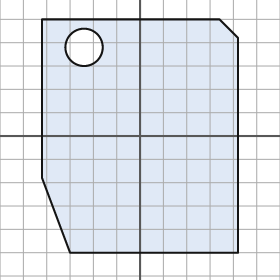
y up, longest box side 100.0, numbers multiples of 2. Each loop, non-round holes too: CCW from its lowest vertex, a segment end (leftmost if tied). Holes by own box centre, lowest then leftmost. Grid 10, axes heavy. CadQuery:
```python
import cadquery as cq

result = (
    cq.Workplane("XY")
    .moveTo(-30.0, -50.0)
    .lineTo(42.0, -50.0)
    .lineTo(42.0, 42.0)
    .lineTo(34.0, 50.0)
    .lineTo(-42.0, 50.0)
    .lineTo(-42.0, -18.0)
    .close()
    .moveTo(-24.0, 38.0)
    .circle(8.0)
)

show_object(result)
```